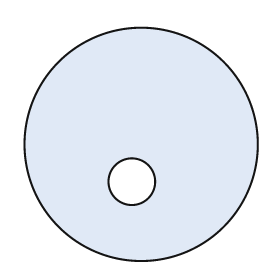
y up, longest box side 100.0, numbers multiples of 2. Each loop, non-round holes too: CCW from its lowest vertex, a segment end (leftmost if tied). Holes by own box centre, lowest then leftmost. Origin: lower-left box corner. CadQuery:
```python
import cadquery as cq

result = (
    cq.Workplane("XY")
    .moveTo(50.0, 50.0)
    .circle(50.0)
    .moveTo(46.0, 34.0)
    .circle(10.0)
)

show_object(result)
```